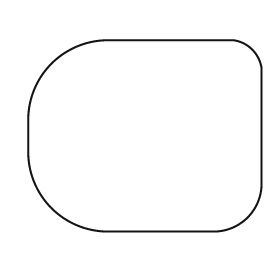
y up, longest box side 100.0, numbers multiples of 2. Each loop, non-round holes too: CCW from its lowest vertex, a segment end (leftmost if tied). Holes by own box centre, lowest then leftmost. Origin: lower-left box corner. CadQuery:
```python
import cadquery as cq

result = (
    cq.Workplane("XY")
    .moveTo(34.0, 0.0)
    .lineTo(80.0, 0.0)
    .threePointArc((94.0, 6.0), (100.0, 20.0))
    .lineTo(100.0, 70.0)
    .threePointArc((96.0, 78.0), (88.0, 82.0))
    .lineTo(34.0, 82.0)
    .threePointArc((10.0, 72.0), (0.0, 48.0))
    .lineTo(0.0, 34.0)
    .threePointArc((10.0, 10.0), (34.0, 0.0))
    .close()
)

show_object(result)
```